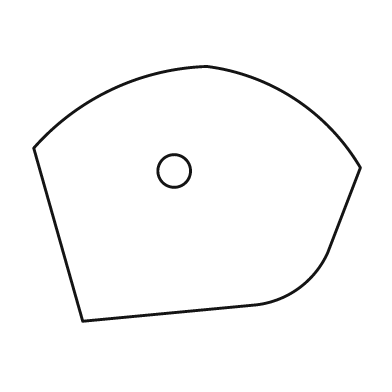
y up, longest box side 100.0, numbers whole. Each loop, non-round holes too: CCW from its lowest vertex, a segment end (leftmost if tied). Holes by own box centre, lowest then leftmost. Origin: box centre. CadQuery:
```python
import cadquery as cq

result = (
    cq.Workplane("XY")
    .moveTo(-35.0, -39.0)
    .lineTo(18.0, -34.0)
    .threePointArc((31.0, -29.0), (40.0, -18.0))
    .lineTo(50.0, 8.0)
    .threePointArc((30.0, 29.0), (3.0, 39.0))
    .threePointArc((-26.0, 32.0), (-50.0, 14.0))
    .close()
    .moveTo(-7.0, 7.0)
    .circle(5.0)
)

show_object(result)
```